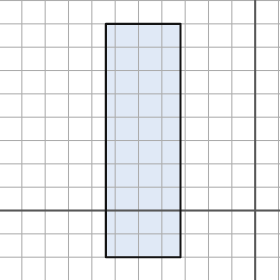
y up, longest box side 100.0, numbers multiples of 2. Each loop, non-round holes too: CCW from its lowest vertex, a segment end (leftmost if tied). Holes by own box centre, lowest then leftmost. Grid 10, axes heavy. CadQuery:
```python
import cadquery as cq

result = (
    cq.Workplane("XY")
    .moveTo(-64.0, -20.0)
    .lineTo(-32.0, -20.0)
    .lineTo(-32.0, 80.0)
    .lineTo(-64.0, 80.0)
    .close()
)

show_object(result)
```